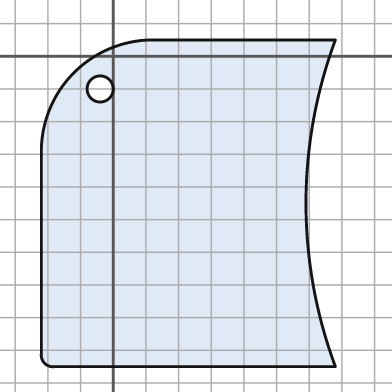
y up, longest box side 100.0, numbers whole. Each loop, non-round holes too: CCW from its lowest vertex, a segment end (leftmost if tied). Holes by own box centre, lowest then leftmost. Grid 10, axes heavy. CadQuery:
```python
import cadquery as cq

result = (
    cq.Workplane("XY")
    .moveTo(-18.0, -95.0)
    .lineTo(68.0, -95.0)
    .threePointArc((59.0, -45.0), (68.0, 5.0))
    .lineTo(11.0, 5.0)
    .threePointArc((-12.0, -5.0), (-22.0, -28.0))
    .lineTo(-22.0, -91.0)
    .threePointArc((-21.0, -94.0), (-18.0, -95.0))
    .close()
    .moveTo(-4.0, -10.0)
    .circle(4.0)
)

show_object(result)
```